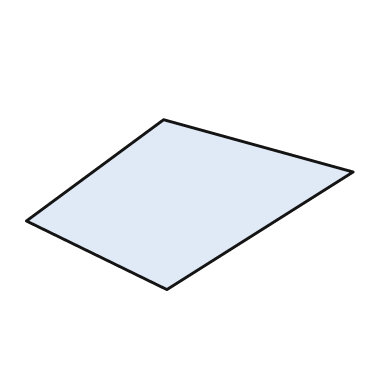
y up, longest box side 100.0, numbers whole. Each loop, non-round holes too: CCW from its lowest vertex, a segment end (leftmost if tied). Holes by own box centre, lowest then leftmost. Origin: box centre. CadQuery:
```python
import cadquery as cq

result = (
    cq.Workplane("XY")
    .moveTo(-7.0, -26.0)
    .lineTo(50.0, 10.0)
    .lineTo(-8.0, 26.0)
    .lineTo(-50.0, -5.0)
    .close()
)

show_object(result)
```